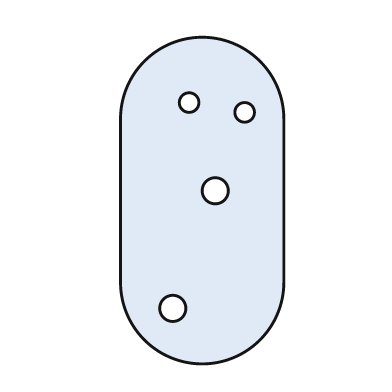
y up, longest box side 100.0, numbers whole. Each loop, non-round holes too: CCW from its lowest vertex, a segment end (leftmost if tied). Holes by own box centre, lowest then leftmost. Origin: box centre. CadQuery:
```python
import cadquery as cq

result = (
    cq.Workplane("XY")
    .moveTo(-25.0, -25.0)
    .threePointArc((0.0, -50.0), (25.0, -25.0))
    .lineTo(25.0, 25.0)
    .threePointArc((0.0, 50.0), (-25.0, 25.0))
    .close()
    .moveTo(-9.0, -33.0)
    .circle(4.0)
    .moveTo(4.0, 3.0)
    .circle(4.0)
    .moveTo(13.0, 27.0)
    .circle(3.0)
    .moveTo(-4.0, 30.0)
    .circle(3.0)
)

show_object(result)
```